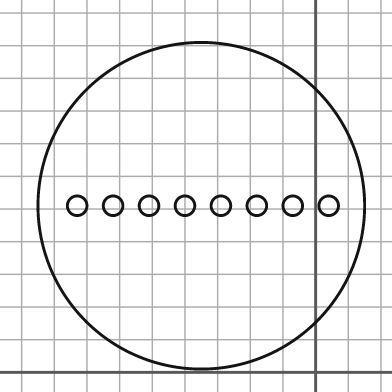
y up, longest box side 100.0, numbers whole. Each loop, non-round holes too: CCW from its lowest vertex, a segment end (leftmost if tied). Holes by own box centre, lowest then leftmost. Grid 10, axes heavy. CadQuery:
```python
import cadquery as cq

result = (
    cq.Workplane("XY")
    .moveTo(-35.0, 51.0)
    .circle(50.0)
    .moveTo(-73.0, 51.0)
    .circle(3.0)
    .moveTo(-62.0, 51.0)
    .circle(3.0)
    .moveTo(-51.0, 51.0)
    .circle(3.0)
    .moveTo(-40.0, 51.0)
    .circle(3.0)
    .moveTo(-29.0, 51.0)
    .circle(3.0)
    .moveTo(-18.0, 51.0)
    .circle(3.0)
    .moveTo(-7.0, 51.0)
    .circle(3.0)
    .moveTo(4.0, 51.0)
    .circle(3.0)
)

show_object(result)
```